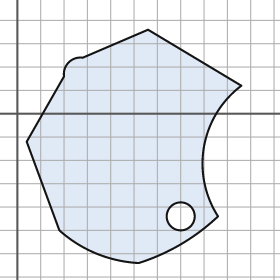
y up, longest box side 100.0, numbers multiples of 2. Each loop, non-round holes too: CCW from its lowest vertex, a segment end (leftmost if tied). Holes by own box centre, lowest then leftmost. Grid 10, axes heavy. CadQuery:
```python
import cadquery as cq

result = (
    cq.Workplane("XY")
    .moveTo(52.0, -64.0)
    .threePointArc((70.0, -56.0), (86.0, -44.0))
    .threePointArc((80.0, -14.0), (96.0, 12.0))
    .lineTo(56.0, 36.0)
    .lineTo(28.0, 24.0)
    .threePointArc((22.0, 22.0), (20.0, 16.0))
    .lineTo(4.0, -12.0)
    .lineTo(18.0, -50.0)
    .threePointArc((34.0, -60.0), (52.0, -64.0))
    .close()
    .moveTo(70.0, -44.0)
    .circle(6.0)
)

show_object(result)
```